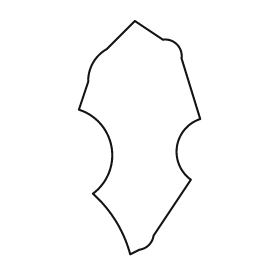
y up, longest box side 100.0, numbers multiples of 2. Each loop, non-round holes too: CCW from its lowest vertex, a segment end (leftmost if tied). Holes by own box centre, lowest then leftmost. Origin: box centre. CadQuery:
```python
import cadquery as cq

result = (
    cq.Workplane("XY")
    .moveTo(-4.0, -50.0)
    .lineTo(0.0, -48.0)
    .threePointArc((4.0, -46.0), (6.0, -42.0))
    .lineTo(22.0, -18.0)
    .threePointArc((16.0, -4.0), (26.0, 8.0))
    .lineTo(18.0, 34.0)
    .threePointArc((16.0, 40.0), (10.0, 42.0))
    .lineTo(-2.0, 50.0)
    .lineTo(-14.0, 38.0)
    .threePointArc((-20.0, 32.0), (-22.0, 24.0))
    .lineTo(-26.0, 12.0)
    .threePointArc((-12.0, -4.0), (-20.0, -24.0))
    .threePointArc((-10.0, -36.0), (-4.0, -50.0))
    .close()
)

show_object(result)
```